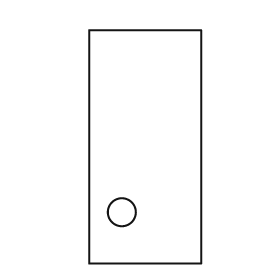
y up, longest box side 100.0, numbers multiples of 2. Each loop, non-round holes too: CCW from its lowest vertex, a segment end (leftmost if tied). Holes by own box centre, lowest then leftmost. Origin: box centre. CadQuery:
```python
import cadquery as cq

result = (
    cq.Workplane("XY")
    .moveTo(-24.0, -50.0)
    .lineTo(24.0, -50.0)
    .lineTo(24.0, 50.0)
    .lineTo(-24.0, 50.0)
    .close()
    .moveTo(-10.0, -28.0)
    .circle(6.0)
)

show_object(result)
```